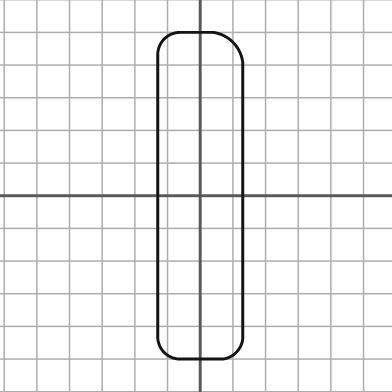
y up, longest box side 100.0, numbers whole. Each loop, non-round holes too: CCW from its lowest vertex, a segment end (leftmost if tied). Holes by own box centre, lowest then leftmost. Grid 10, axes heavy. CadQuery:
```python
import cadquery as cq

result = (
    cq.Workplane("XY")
    .moveTo(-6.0, -50.0)
    .lineTo(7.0, -50.0)
    .threePointArc((11.0, -48.0), (13.0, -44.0))
    .lineTo(13.0, 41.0)
    .threePointArc((10.0, 47.0), (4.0, 50.0))
    .lineTo(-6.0, 50.0)
    .threePointArc((-11.0, 48.0), (-13.0, 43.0))
    .lineTo(-13.0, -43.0)
    .threePointArc((-11.0, -48.0), (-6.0, -50.0))
    .close()
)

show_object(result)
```